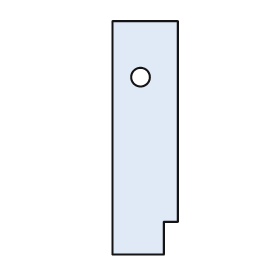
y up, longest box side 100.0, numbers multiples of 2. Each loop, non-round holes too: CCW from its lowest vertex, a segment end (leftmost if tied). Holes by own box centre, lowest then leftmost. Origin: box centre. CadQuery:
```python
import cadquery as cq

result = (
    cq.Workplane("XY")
    .moveTo(-14.0, -50.0)
    .lineTo(8.0, -50.0)
    .lineTo(8.0, -36.0)
    .lineTo(14.0, -36.0)
    .lineTo(14.0, 50.0)
    .lineTo(-14.0, 50.0)
    .close()
    .moveTo(-2.0, 26.0)
    .circle(4.0)
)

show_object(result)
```